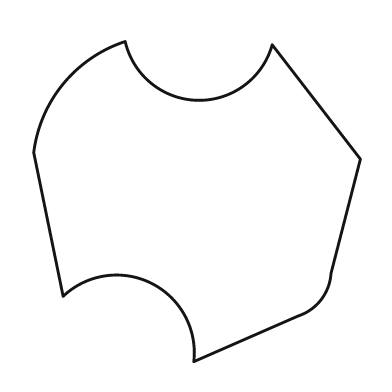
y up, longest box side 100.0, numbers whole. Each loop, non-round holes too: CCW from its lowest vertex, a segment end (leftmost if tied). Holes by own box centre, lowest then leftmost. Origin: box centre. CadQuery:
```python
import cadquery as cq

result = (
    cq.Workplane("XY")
    .moveTo(-1.0, -49.0)
    .lineTo(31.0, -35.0)
    .threePointArc((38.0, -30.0), (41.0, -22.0))
    .lineTo(50.0, 13.0)
    .lineTo(23.0, 48.0)
    .threePointArc((0.0, 31.0), (-22.0, 49.0))
    .threePointArc((-41.0, 36.0), (-50.0, 15.0))
    .lineTo(-41.0, -29.0)
    .threePointArc((-14.0, -25.0), (-1.0, -49.0))
    .close()
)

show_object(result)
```